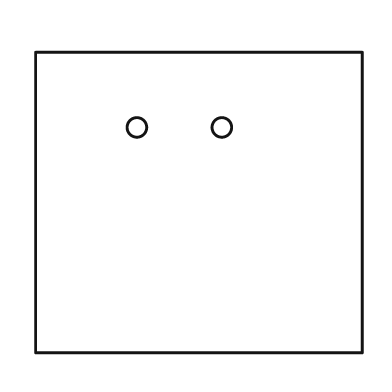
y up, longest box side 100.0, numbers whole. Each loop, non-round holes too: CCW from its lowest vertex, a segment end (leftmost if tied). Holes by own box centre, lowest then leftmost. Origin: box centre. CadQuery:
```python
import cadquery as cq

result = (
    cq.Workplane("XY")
    .moveTo(-50.0, -46.0)
    .lineTo(50.0, -46.0)
    .lineTo(50.0, 46.0)
    .lineTo(-50.0, 46.0)
    .close()
    .moveTo(-19.0, 23.0)
    .circle(3.0)
    .moveTo(7.0, 23.0)
    .circle(3.0)
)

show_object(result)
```